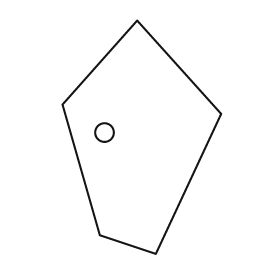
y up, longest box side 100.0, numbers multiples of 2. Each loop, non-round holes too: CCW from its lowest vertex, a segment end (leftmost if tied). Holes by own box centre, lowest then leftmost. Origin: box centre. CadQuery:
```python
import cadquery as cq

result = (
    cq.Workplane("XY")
    .moveTo(6.0, -50.0)
    .lineTo(34.0, 10.0)
    .lineTo(-2.0, 50.0)
    .lineTo(-34.0, 14.0)
    .lineTo(-18.0, -42.0)
    .close()
    .moveTo(-16.0, 2.0)
    .circle(4.0)
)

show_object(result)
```